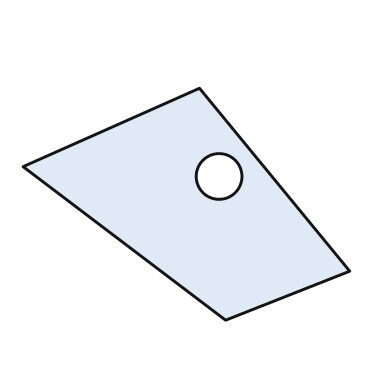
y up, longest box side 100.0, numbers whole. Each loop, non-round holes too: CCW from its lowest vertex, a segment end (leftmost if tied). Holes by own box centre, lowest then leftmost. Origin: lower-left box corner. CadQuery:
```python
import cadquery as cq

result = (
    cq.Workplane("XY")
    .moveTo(62.0, 0.0)
    .lineTo(100.0, 15.0)
    .lineTo(54.0, 71.0)
    .lineTo(0.0, 47.0)
    .close()
    .moveTo(60.0, 44.0)
    .circle(7.0)
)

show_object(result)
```